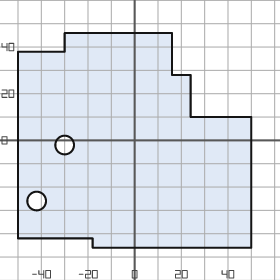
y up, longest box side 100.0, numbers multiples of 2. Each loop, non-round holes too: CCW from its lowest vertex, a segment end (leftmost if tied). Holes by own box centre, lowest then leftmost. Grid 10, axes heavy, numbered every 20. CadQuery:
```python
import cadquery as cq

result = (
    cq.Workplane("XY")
    .moveTo(-18.0, -46.0)
    .lineTo(50.0, -46.0)
    .lineTo(50.0, 10.0)
    .lineTo(24.0, 10.0)
    .lineTo(24.0, 28.0)
    .lineTo(16.0, 28.0)
    .lineTo(16.0, 46.0)
    .lineTo(-30.0, 46.0)
    .lineTo(-30.0, 38.0)
    .lineTo(-50.0, 38.0)
    .lineTo(-50.0, -42.0)
    .lineTo(-18.0, -42.0)
    .close()
    .moveTo(-42.0, -26.0)
    .circle(4.0)
    .moveTo(-30.0, -2.0)
    .circle(4.0)
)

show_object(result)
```